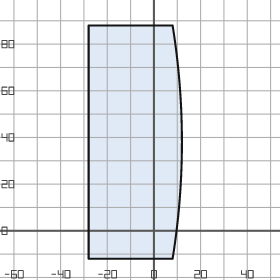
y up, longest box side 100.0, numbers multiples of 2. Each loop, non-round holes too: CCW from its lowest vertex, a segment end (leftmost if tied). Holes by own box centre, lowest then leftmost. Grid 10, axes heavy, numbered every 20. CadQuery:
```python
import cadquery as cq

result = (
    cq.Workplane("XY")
    .moveTo(-28.0, -12.0)
    .lineTo(8.0, -12.0)
    .threePointArc((12.0, 38.0), (8.0, 88.0))
    .lineTo(-28.0, 88.0)
    .close()
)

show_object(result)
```